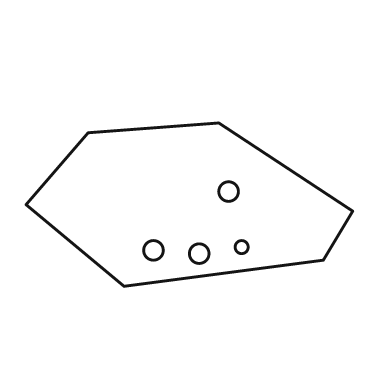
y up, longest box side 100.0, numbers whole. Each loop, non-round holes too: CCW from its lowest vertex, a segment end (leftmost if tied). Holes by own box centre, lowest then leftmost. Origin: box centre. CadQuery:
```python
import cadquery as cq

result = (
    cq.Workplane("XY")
    .moveTo(-20.0, -25.0)
    .lineTo(41.0, -17.0)
    .lineTo(50.0, -2.0)
    .lineTo(9.0, 25.0)
    .lineTo(-31.0, 22.0)
    .lineTo(-50.0, 0.0)
    .close()
    .moveTo(3.0, -15.0)
    .circle(3.0)
    .moveTo(-11.0, -14.0)
    .circle(3.0)
    .moveTo(16.0, -13.0)
    .circle(2.0)
    .moveTo(12.0, 4.0)
    .circle(3.0)
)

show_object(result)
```